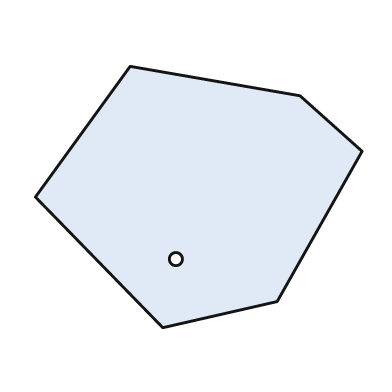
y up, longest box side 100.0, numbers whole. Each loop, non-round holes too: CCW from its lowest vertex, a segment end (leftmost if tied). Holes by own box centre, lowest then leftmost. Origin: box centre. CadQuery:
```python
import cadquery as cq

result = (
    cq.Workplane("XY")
    .moveTo(-11.0, -40.0)
    .lineTo(24.0, -32.0)
    .lineTo(50.0, 14.0)
    .lineTo(31.0, 31.0)
    .lineTo(-21.0, 40.0)
    .lineTo(-50.0, 0.0)
    .close()
    .moveTo(-7.0, -19.0)
    .circle(2.0)
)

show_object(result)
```